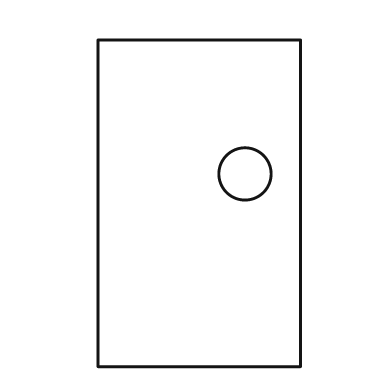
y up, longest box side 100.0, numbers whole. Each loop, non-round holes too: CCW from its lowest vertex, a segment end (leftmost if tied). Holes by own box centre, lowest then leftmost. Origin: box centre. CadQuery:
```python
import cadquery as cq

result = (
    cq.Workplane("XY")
    .moveTo(-31.0, -50.0)
    .lineTo(31.0, -50.0)
    .lineTo(31.0, 50.0)
    .lineTo(-31.0, 50.0)
    .close()
    .moveTo(14.0, 9.0)
    .circle(8.0)
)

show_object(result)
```